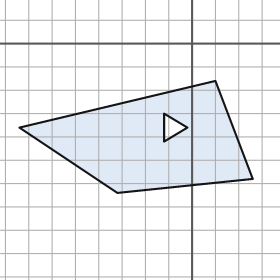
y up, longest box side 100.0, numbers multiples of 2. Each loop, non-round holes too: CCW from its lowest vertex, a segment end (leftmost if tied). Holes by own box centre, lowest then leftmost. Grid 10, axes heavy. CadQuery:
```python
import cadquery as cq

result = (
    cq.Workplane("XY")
    .moveTo(-32.0, -64.0)
    .lineTo(26.0, -58.0)
    .lineTo(10.0, -16.0)
    .lineTo(-74.0, -36.0)
    .close()
    .moveTo(-12.0, -42.0)
    .lineTo(-2.0, -36.0)
    .lineTo(-12.0, -30.0)
    .close()
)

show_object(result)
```